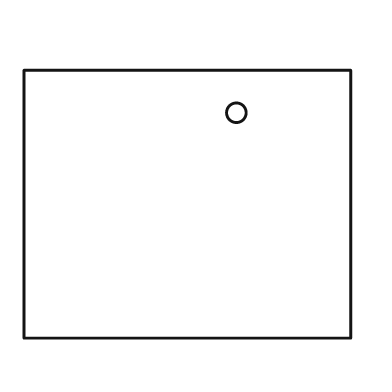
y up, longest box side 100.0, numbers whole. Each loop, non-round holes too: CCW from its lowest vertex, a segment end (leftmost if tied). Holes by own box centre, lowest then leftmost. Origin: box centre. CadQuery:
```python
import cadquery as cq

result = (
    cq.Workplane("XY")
    .moveTo(-50.0, -41.0)
    .lineTo(50.0, -41.0)
    .lineTo(50.0, 41.0)
    .lineTo(-50.0, 41.0)
    .close()
    .moveTo(15.0, 28.0)
    .circle(3.0)
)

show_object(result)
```